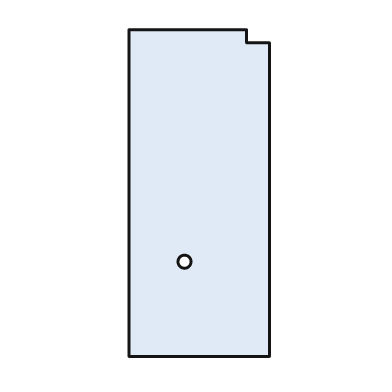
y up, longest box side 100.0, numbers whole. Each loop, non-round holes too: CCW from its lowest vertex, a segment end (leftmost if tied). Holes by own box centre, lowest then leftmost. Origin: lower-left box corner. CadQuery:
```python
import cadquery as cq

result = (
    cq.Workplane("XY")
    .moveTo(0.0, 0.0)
    .lineTo(43.0, 0.0)
    .lineTo(43.0, 96.0)
    .lineTo(36.0, 96.0)
    .lineTo(36.0, 100.0)
    .lineTo(0.0, 100.0)
    .close()
    .moveTo(17.0, 29.0)
    .circle(2.0)
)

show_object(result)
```